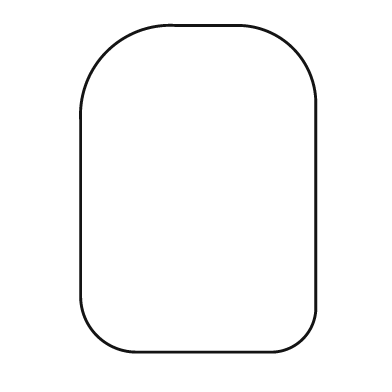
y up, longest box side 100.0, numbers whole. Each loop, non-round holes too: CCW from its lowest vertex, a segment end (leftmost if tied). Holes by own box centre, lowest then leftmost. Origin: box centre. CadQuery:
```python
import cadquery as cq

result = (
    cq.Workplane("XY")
    .moveTo(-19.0, -50.0)
    .lineTo(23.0, -50.0)
    .threePointArc((32.0, -46.0), (36.0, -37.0))
    .lineTo(36.0, 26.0)
    .threePointArc((29.0, 43.0), (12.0, 50.0))
    .lineTo(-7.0, 50.0)
    .threePointArc((-28.0, 42.0), (-36.0, 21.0))
    .lineTo(-36.0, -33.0)
    .threePointArc((-31.0, -45.0), (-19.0, -50.0))
    .close()
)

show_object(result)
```